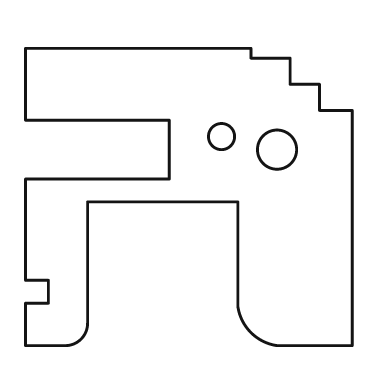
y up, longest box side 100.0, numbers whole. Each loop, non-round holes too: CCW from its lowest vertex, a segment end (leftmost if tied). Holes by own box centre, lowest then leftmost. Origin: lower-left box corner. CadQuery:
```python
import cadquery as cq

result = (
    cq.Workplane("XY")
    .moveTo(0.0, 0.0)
    .lineTo(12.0, 0.0)
    .threePointArc((17.0, 2.0), (19.0, 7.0))
    .lineTo(19.0, 44.0)
    .lineTo(65.0, 44.0)
    .lineTo(65.0, 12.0)
    .threePointArc((69.0, 4.0), (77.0, 0.0))
    .lineTo(100.0, 0.0)
    .lineTo(100.0, 72.0)
    .lineTo(90.0, 72.0)
    .lineTo(90.0, 80.0)
    .lineTo(81.0, 80.0)
    .lineTo(81.0, 88.0)
    .lineTo(69.0, 88.0)
    .lineTo(69.0, 91.0)
    .lineTo(0.0, 91.0)
    .lineTo(0.0, 69.0)
    .lineTo(44.0, 69.0)
    .lineTo(44.0, 51.0)
    .lineTo(0.0, 51.0)
    .lineTo(0.0, 20.0)
    .lineTo(7.0, 20.0)
    .lineTo(7.0, 13.0)
    .lineTo(0.0, 13.0)
    .close()
    .moveTo(77.0, 60.0)
    .circle(6.0)
    .moveTo(60.0, 64.0)
    .circle(4.0)
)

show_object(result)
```